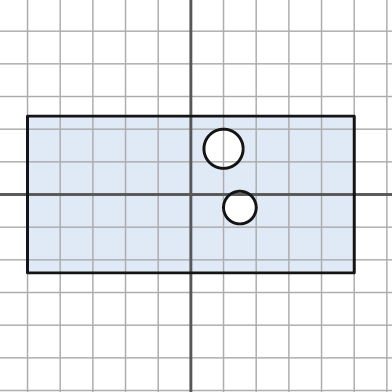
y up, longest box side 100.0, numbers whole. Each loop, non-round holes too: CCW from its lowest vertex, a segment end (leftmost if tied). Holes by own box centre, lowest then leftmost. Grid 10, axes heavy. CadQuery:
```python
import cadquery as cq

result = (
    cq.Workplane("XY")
    .moveTo(-50.0, -24.0)
    .lineTo(50.0, -24.0)
    .lineTo(50.0, 24.0)
    .lineTo(-50.0, 24.0)
    .close()
    .moveTo(15.0, -4.0)
    .circle(5.0)
    .moveTo(10.0, 14.0)
    .circle(6.0)
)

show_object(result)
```